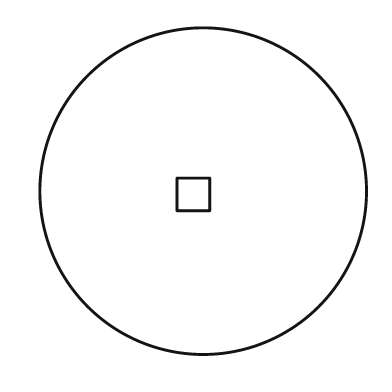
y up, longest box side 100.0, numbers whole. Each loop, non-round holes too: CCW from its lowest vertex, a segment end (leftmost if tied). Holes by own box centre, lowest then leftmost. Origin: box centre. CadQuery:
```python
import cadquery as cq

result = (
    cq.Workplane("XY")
    .moveTo(0.0, 0.0)
    .circle(50.0)
    .moveTo(-8.0, -6.0)
    .lineTo(2.0, -6.0)
    .lineTo(2.0, 4.0)
    .lineTo(-8.0, 4.0)
    .close()
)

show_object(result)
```